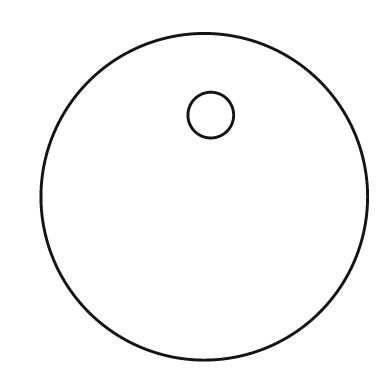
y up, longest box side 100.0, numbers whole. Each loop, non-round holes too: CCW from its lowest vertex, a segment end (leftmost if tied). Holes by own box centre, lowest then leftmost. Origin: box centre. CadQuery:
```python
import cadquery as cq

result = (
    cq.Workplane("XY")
    .moveTo(0.0, 0.0)
    .circle(50.0)
    .moveTo(2.0, 25.0)
    .circle(7.0)
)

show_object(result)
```